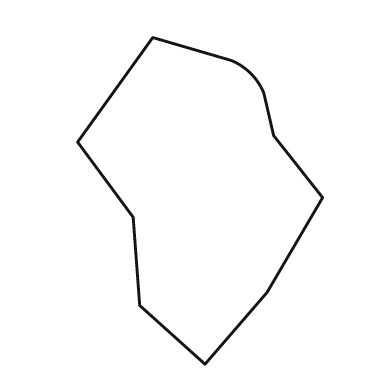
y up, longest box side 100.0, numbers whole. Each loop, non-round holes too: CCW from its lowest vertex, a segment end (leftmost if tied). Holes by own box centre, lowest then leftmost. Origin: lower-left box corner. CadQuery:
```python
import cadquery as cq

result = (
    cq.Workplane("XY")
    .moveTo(39.0, 0.0)
    .lineTo(58.0, 22.0)
    .lineTo(75.0, 51.0)
    .lineTo(60.0, 70.0)
    .lineTo(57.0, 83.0)
    .threePointArc((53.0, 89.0), (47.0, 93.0))
    .lineTo(23.0, 100.0)
    .lineTo(0.0, 68.0)
    .lineTo(17.0, 45.0)
    .lineTo(19.0, 18.0)
    .close()
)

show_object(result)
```